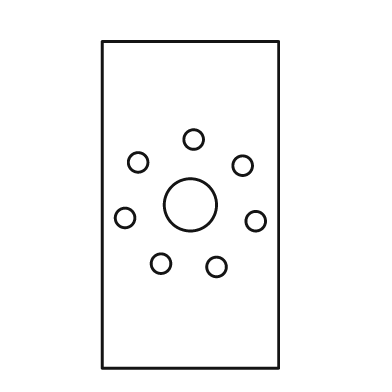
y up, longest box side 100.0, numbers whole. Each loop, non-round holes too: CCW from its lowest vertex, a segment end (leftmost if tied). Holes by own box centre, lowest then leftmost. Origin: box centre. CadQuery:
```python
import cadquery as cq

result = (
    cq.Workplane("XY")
    .moveTo(-27.0, -50.0)
    .lineTo(27.0, -50.0)
    .lineTo(27.0, 50.0)
    .lineTo(-27.0, 50.0)
    .close()
    .moveTo(8.0, -19.0)
    .circle(3.0)
    .moveTo(-9.0, -18.0)
    .circle(3.0)
    .moveTo(20.0, -5.0)
    .circle(3.0)
    .moveTo(-20.0, -4.0)
    .circle(3.0)
    .moveTo(0.0, 0.0)
    .circle(8.0)
    .moveTo(16.0, 12.0)
    .circle(3.0)
    .moveTo(-16.0, 13.0)
    .circle(3.0)
    .moveTo(1.0, 20.0)
    .circle(3.0)
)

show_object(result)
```